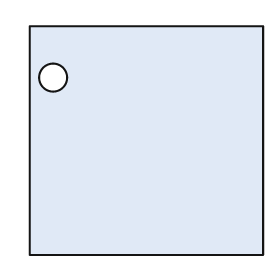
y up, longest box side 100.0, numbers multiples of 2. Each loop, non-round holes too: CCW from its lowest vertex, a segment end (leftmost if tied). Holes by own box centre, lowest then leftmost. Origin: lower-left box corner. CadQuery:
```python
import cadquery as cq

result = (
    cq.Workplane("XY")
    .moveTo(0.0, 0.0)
    .lineTo(100.0, 0.0)
    .lineTo(100.0, 98.0)
    .lineTo(0.0, 98.0)
    .close()
    .moveTo(10.0, 76.0)
    .circle(6.0)
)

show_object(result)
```